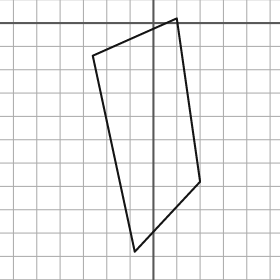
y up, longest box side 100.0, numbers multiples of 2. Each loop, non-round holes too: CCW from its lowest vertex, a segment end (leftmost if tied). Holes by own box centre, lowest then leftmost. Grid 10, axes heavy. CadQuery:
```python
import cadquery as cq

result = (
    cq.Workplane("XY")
    .moveTo(-8.0, -98.0)
    .lineTo(20.0, -68.0)
    .lineTo(10.0, 2.0)
    .lineTo(-26.0, -14.0)
    .close()
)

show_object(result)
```